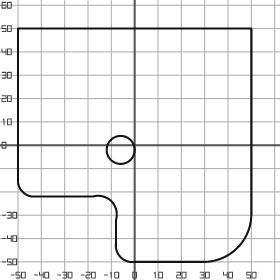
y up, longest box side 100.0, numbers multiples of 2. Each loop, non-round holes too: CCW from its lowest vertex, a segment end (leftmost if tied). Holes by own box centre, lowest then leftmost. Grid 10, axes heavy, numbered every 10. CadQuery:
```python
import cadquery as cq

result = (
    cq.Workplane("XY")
    .moveTo(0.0, -50.0)
    .lineTo(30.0, -50.0)
    .threePointArc((44.0, -44.0), (50.0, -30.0))
    .lineTo(50.0, 50.0)
    .lineTo(-50.0, 50.0)
    .lineTo(-50.0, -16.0)
    .threePointArc((-48.0, -20.0), (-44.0, -22.0))
    .lineTo(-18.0, -22.0)
    .threePointArc((-10.0, -24.0), (-8.0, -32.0))
    .lineTo(-8.0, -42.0)
    .threePointArc((-6.0, -48.0), (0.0, -50.0))
    .close()
    .moveTo(-6.0, -2.0)
    .circle(6.0)
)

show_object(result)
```